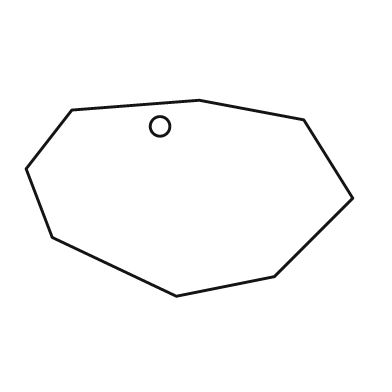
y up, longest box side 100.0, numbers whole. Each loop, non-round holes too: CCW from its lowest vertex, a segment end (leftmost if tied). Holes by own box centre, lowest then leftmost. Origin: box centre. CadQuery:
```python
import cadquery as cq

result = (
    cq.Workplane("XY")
    .moveTo(-4.0, -30.0)
    .lineTo(26.0, -24.0)
    .lineTo(50.0, 0.0)
    .lineTo(35.0, 24.0)
    .lineTo(3.0, 30.0)
    .lineTo(-36.0, 27.0)
    .lineTo(-50.0, 9.0)
    .lineTo(-42.0, -12.0)
    .close()
    .moveTo(-9.0, 22.0)
    .circle(3.0)
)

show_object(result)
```